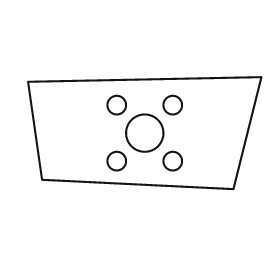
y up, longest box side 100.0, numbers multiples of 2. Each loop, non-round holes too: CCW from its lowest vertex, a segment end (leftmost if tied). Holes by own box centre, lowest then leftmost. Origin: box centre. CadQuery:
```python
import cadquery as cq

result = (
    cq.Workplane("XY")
    .moveTo(38.0, -24.0)
    .lineTo(50.0, 24.0)
    .lineTo(-50.0, 22.0)
    .lineTo(-44.0, -20.0)
    .close()
    .moveTo(-12.0, -12.0)
    .circle(4.0)
    .moveTo(12.0, -12.0)
    .circle(4.0)
    .moveTo(0.0, 0.0)
    .circle(8.0)
    .moveTo(-12.0, 12.0)
    .circle(4.0)
    .moveTo(12.0, 12.0)
    .circle(4.0)
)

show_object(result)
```